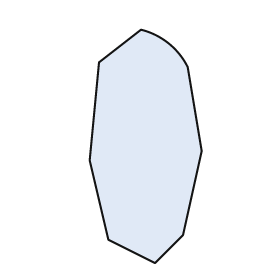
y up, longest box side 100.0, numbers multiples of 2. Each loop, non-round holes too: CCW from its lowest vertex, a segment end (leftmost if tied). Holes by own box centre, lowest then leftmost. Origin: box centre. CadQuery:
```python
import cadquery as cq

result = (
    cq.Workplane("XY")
    .moveTo(4.0, -50.0)
    .lineTo(16.0, -38.0)
    .lineTo(24.0, -2.0)
    .lineTo(18.0, 34.0)
    .threePointArc((10.0, 44.0), (-2.0, 50.0))
    .lineTo(-20.0, 36.0)
    .lineTo(-24.0, -6.0)
    .lineTo(-16.0, -40.0)
    .close()
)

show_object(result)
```